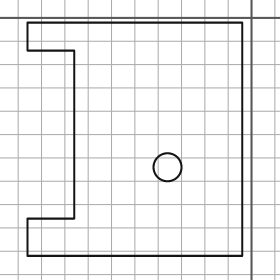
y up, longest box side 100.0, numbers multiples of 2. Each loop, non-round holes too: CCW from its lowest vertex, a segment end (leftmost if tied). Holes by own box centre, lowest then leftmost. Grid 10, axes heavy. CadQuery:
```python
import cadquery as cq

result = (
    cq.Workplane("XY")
    .moveTo(-96.0, -102.0)
    .lineTo(-4.0, -102.0)
    .lineTo(-4.0, -2.0)
    .lineTo(-96.0, -2.0)
    .lineTo(-96.0, -14.0)
    .lineTo(-76.0, -14.0)
    .lineTo(-76.0, -86.0)
    .lineTo(-96.0, -86.0)
    .close()
    .moveTo(-36.0, -64.0)
    .circle(6.0)
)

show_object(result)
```